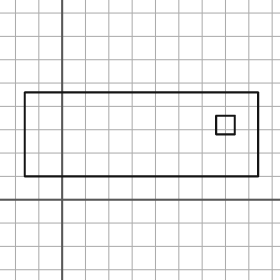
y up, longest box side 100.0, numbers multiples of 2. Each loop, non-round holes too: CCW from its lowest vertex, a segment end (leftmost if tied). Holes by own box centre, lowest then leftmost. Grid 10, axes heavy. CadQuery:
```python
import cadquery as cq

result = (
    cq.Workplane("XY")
    .moveTo(-16.0, 10.0)
    .lineTo(84.0, 10.0)
    .lineTo(84.0, 46.0)
    .lineTo(-16.0, 46.0)
    .close()
    .moveTo(66.0, 28.0)
    .lineTo(74.0, 28.0)
    .lineTo(74.0, 36.0)
    .lineTo(66.0, 36.0)
    .close()
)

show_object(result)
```